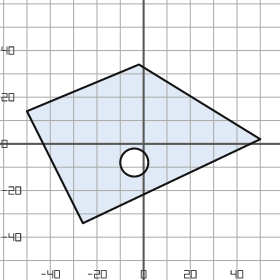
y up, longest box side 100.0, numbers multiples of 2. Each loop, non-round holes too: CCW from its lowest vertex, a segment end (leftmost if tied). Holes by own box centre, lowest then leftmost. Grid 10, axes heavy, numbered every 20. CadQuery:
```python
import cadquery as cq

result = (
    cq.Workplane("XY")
    .moveTo(-26.0, -34.0)
    .lineTo(50.0, 2.0)
    .lineTo(-2.0, 34.0)
    .lineTo(-50.0, 14.0)
    .close()
    .moveTo(-4.0, -8.0)
    .circle(6.0)
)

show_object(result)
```